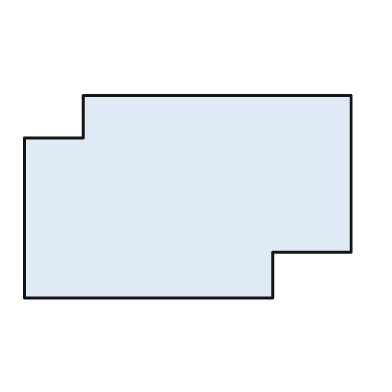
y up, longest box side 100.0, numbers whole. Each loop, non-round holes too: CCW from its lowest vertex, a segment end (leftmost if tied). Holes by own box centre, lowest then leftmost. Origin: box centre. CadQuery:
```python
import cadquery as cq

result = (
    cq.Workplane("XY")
    .moveTo(-50.0, -31.0)
    .lineTo(26.0, -31.0)
    .lineTo(26.0, -17.0)
    .lineTo(50.0, -17.0)
    .lineTo(50.0, 31.0)
    .lineTo(-32.0, 31.0)
    .lineTo(-32.0, 18.0)
    .lineTo(-50.0, 18.0)
    .close()
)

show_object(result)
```